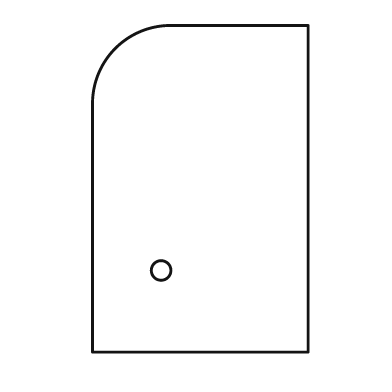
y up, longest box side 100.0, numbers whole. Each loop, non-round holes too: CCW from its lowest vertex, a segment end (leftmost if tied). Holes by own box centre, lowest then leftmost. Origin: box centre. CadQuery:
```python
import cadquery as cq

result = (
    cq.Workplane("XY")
    .moveTo(-33.0, -50.0)
    .lineTo(33.0, -50.0)
    .lineTo(33.0, 50.0)
    .lineTo(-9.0, 50.0)
    .threePointArc((-26.0, 43.0), (-33.0, 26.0))
    .close()
    .moveTo(-12.0, -25.0)
    .circle(3.0)
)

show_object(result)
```